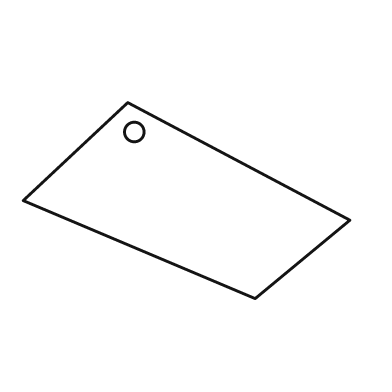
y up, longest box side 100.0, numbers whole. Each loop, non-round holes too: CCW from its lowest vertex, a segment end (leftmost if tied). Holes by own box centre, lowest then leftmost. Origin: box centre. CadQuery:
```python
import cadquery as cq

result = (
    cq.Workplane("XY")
    .moveTo(21.0, -30.0)
    .lineTo(50.0, -6.0)
    .lineTo(-18.0, 30.0)
    .lineTo(-50.0, 0.0)
    .close()
    .moveTo(-16.0, 21.0)
    .circle(3.0)
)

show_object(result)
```